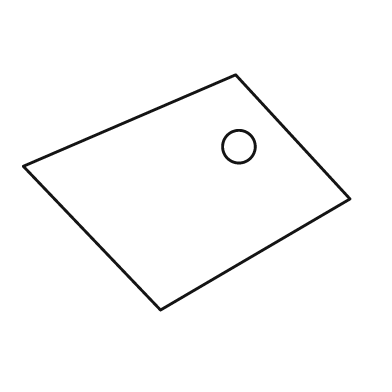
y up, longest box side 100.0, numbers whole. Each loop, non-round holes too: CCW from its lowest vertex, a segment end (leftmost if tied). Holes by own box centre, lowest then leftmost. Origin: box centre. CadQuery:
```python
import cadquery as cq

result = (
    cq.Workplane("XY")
    .moveTo(-8.0, -36.0)
    .lineTo(50.0, -2.0)
    .lineTo(15.0, 36.0)
    .lineTo(-50.0, 8.0)
    .close()
    .moveTo(16.0, 14.0)
    .circle(5.0)
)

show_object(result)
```